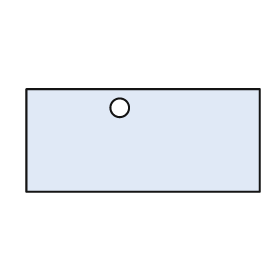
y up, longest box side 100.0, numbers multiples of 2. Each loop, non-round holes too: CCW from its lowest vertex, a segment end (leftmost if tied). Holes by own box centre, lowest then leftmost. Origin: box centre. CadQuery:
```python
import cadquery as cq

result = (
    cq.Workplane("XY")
    .moveTo(-50.0, -22.0)
    .lineTo(50.0, -22.0)
    .lineTo(50.0, 22.0)
    .lineTo(-50.0, 22.0)
    .close()
    .moveTo(-10.0, 14.0)
    .circle(4.0)
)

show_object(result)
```